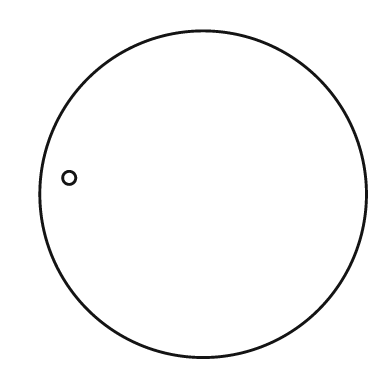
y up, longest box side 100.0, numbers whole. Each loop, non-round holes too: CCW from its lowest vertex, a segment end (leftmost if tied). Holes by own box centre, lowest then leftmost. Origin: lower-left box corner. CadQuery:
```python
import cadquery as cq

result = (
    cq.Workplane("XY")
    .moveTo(50.0, 50.0)
    .circle(50.0)
    .moveTo(9.0, 55.0)
    .circle(2.0)
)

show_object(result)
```